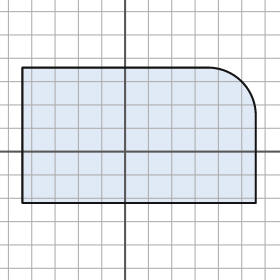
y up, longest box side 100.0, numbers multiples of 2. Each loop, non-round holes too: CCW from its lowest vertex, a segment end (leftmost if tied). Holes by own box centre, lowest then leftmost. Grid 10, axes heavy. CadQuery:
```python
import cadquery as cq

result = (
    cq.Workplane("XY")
    .moveTo(-44.0, -22.0)
    .lineTo(56.0, -22.0)
    .lineTo(56.0, 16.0)
    .threePointArc((50.0, 30.0), (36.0, 36.0))
    .lineTo(-44.0, 36.0)
    .close()
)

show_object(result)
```